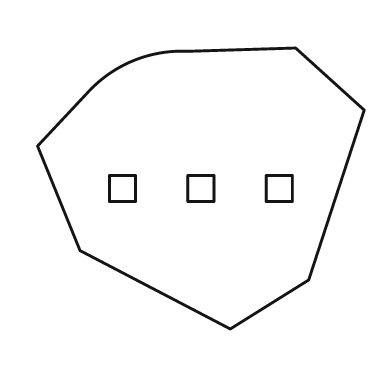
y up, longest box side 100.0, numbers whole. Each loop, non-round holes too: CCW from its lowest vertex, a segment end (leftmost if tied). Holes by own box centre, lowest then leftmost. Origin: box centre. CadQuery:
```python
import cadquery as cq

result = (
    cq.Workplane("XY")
    .moveTo(9.0, -43.0)
    .lineTo(33.0, -28.0)
    .lineTo(50.0, 24.0)
    .lineTo(29.0, 43.0)
    .lineTo(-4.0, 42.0)
    .threePointArc((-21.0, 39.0), (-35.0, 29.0))
    .lineTo(-50.0, 13.0)
    .lineTo(-37.0, -19.0)
    .close()
    .moveTo(-28.0, -4.0)
    .lineTo(-20.0, -4.0)
    .lineTo(-20.0, 4.0)
    .lineTo(-28.0, 4.0)
    .close()
    .moveTo(-4.0, -4.0)
    .lineTo(4.0, -4.0)
    .lineTo(4.0, 4.0)
    .lineTo(-4.0, 4.0)
    .close()
    .moveTo(20.0, -4.0)
    .lineTo(28.0, -4.0)
    .lineTo(28.0, 4.0)
    .lineTo(20.0, 4.0)
    .close()
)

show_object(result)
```